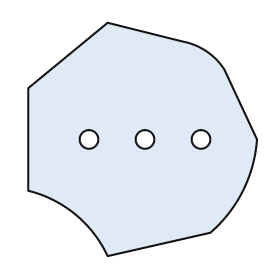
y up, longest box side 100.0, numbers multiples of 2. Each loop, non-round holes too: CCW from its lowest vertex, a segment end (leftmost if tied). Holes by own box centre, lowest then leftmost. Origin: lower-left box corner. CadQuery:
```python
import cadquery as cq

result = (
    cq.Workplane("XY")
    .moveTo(34.0, 0.0)
    .lineTo(78.0, 10.0)
    .threePointArc((92.0, 28.0), (98.0, 50.0))
    .lineTo(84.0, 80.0)
    .threePointArc((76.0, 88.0), (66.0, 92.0))
    .lineTo(34.0, 100.0)
    .lineTo(0.0, 72.0)
    .lineTo(0.0, 28.0)
    .threePointArc((20.0, 18.0), (34.0, 0.0))
    .close()
    .moveTo(26.0, 50.0)
    .circle(4.0)
    .moveTo(50.0, 50.0)
    .circle(4.0)
    .moveTo(74.0, 50.0)
    .circle(4.0)
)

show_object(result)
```